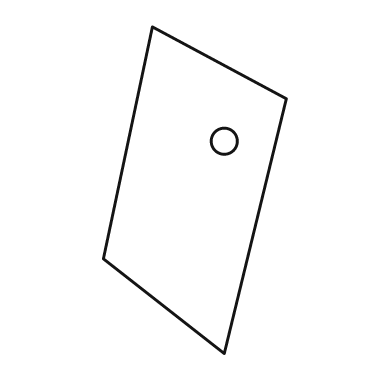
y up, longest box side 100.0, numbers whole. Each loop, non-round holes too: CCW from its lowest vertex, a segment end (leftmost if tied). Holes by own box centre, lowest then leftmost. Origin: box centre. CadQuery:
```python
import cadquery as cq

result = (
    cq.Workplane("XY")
    .moveTo(9.0, -50.0)
    .lineTo(28.0, 28.0)
    .lineTo(-13.0, 50.0)
    .lineTo(-28.0, -21.0)
    .close()
    .moveTo(9.0, 15.0)
    .circle(4.0)
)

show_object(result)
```